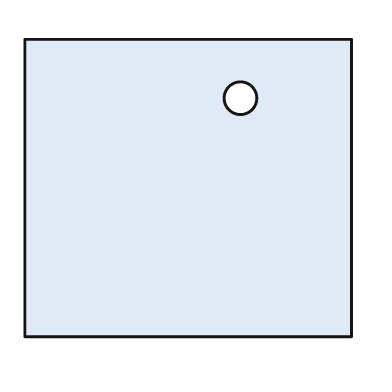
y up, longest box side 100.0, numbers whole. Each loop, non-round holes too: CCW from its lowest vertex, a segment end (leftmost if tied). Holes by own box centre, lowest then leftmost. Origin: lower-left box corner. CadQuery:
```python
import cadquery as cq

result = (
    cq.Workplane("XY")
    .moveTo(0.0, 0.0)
    .lineTo(100.0, 0.0)
    .lineTo(100.0, 91.0)
    .lineTo(0.0, 91.0)
    .close()
    .moveTo(66.0, 73.0)
    .circle(5.0)
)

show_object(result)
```